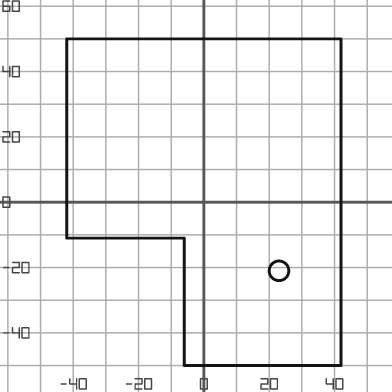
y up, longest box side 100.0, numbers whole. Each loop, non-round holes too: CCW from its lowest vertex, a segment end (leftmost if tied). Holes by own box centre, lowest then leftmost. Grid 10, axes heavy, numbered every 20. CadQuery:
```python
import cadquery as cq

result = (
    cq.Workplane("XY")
    .moveTo(-6.0, -50.0)
    .lineTo(42.0, -50.0)
    .lineTo(42.0, 50.0)
    .lineTo(-42.0, 50.0)
    .lineTo(-42.0, -11.0)
    .lineTo(-6.0, -11.0)
    .close()
    .moveTo(23.0, -21.0)
    .circle(3.0)
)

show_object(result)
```